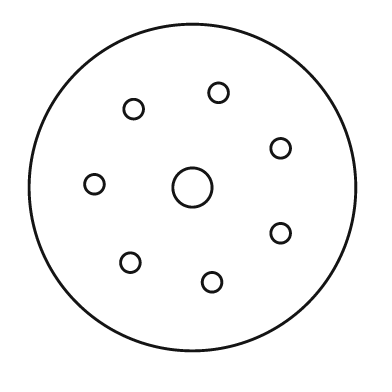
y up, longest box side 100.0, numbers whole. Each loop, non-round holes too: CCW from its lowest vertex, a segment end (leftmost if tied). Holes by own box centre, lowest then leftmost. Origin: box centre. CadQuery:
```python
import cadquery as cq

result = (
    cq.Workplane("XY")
    .moveTo(0.0, 0.0)
    .circle(50.0)
    .moveTo(6.0, -29.0)
    .circle(3.0)
    .moveTo(-19.0, -23.0)
    .circle(3.0)
    .moveTo(27.0, -14.0)
    .circle(3.0)
    .moveTo(0.0, 0.0)
    .circle(6.0)
    .moveTo(-30.0, 1.0)
    .circle(3.0)
    .moveTo(27.0, 12.0)
    .circle(3.0)
    .moveTo(-18.0, 24.0)
    .circle(3.0)
    .moveTo(8.0, 29.0)
    .circle(3.0)
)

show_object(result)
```